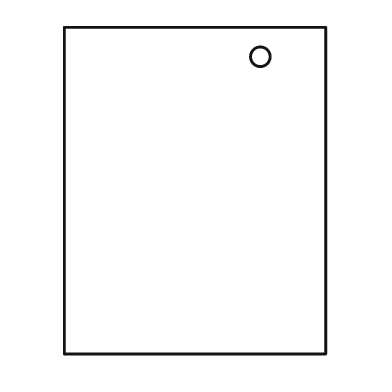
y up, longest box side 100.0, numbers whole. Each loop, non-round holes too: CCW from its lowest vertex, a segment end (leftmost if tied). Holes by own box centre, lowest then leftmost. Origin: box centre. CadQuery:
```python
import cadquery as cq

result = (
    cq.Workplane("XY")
    .moveTo(-40.0, -50.0)
    .lineTo(40.0, -50.0)
    .lineTo(40.0, 50.0)
    .lineTo(-40.0, 50.0)
    .close()
    .moveTo(20.0, 41.0)
    .circle(3.0)
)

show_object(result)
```